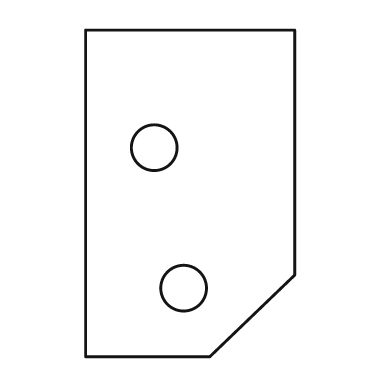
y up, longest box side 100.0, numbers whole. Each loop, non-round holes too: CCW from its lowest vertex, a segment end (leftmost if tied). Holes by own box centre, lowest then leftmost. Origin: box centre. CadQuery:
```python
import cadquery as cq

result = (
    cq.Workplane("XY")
    .moveTo(-32.0, -50.0)
    .lineTo(6.0, -50.0)
    .lineTo(32.0, -25.0)
    .lineTo(32.0, 50.0)
    .lineTo(-32.0, 50.0)
    .close()
    .moveTo(-2.0, -29.0)
    .circle(7.0)
    .moveTo(-11.0, 14.0)
    .circle(7.0)
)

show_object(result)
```